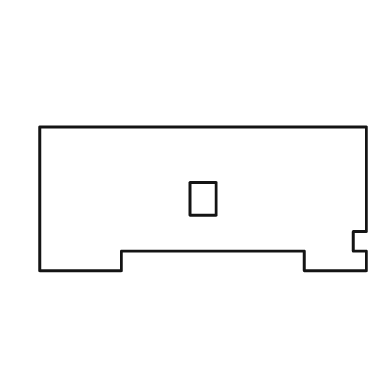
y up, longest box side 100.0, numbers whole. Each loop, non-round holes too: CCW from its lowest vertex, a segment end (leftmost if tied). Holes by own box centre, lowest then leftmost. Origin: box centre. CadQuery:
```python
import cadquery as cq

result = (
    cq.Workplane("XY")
    .moveTo(-50.0, -22.0)
    .lineTo(-25.0, -22.0)
    .lineTo(-25.0, -16.0)
    .lineTo(31.0, -16.0)
    .lineTo(31.0, -22.0)
    .lineTo(50.0, -22.0)
    .lineTo(50.0, -16.0)
    .lineTo(46.0, -16.0)
    .lineTo(46.0, -10.0)
    .lineTo(50.0, -10.0)
    .lineTo(50.0, 22.0)
    .lineTo(-50.0, 22.0)
    .close()
    .moveTo(-4.0, -5.0)
    .lineTo(4.0, -5.0)
    .lineTo(4.0, 5.0)
    .lineTo(-4.0, 5.0)
    .close()
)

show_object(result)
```